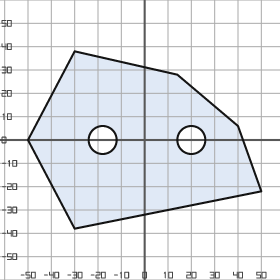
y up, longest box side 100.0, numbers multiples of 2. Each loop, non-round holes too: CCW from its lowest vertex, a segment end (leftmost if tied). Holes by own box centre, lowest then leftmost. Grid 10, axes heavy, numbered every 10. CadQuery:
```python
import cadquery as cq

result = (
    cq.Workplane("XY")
    .moveTo(-30.0, -38.0)
    .lineTo(50.0, -22.0)
    .lineTo(40.0, 6.0)
    .lineTo(14.0, 28.0)
    .lineTo(-30.0, 38.0)
    .lineTo(-50.0, 0.0)
    .close()
    .moveTo(-18.0, 0.0)
    .circle(6.0)
    .moveTo(20.0, 0.0)
    .circle(6.0)
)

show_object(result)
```